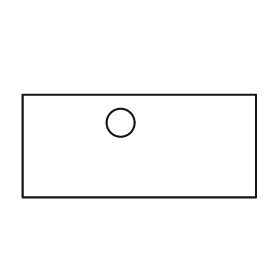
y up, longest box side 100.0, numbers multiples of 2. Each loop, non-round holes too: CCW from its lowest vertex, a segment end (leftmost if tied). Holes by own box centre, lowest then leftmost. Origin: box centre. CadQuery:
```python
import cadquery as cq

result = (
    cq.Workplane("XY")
    .moveTo(-50.0, -22.0)
    .lineTo(50.0, -22.0)
    .lineTo(50.0, 22.0)
    .lineTo(-50.0, 22.0)
    .close()
    .moveTo(-8.0, 10.0)
    .circle(6.0)
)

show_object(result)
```